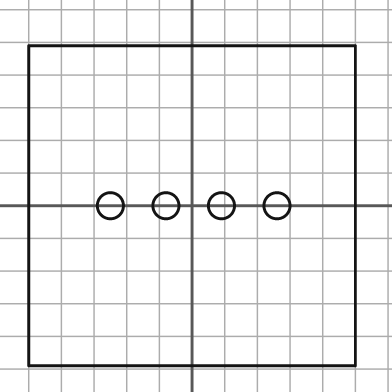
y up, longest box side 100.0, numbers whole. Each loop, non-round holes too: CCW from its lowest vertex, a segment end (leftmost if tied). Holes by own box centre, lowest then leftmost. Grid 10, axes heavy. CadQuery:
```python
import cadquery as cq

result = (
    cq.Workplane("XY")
    .moveTo(-50.0, -49.0)
    .lineTo(50.0, -49.0)
    .lineTo(50.0, 49.0)
    .lineTo(-50.0, 49.0)
    .close()
    .moveTo(-25.0, 0.0)
    .circle(4.0)
    .moveTo(-8.0, 0.0)
    .circle(4.0)
    .moveTo(9.0, 0.0)
    .circle(4.0)
    .moveTo(26.0, 0.0)
    .circle(4.0)
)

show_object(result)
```